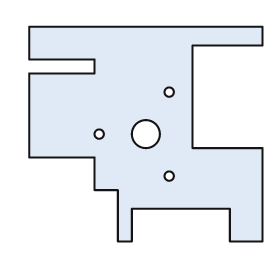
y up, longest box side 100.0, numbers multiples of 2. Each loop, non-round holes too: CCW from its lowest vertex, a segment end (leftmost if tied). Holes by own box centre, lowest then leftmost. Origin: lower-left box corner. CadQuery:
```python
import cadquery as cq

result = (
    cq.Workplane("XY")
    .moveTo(38.0, 0.0)
    .lineTo(44.0, 0.0)
    .lineTo(44.0, 14.0)
    .lineTo(86.0, 14.0)
    .lineTo(86.0, 0.0)
    .lineTo(100.0, 0.0)
    .lineTo(100.0, 40.0)
    .lineTo(70.0, 40.0)
    .lineTo(70.0, 84.0)
    .lineTo(100.0, 84.0)
    .lineTo(100.0, 92.0)
    .lineTo(0.0, 92.0)
    .lineTo(0.0, 78.0)
    .lineTo(28.0, 78.0)
    .lineTo(28.0, 72.0)
    .lineTo(0.0, 72.0)
    .lineTo(0.0, 36.0)
    .lineTo(28.0, 36.0)
    .lineTo(28.0, 22.0)
    .lineTo(38.0, 22.0)
    .close()
    .moveTo(60.0, 28.0)
    .circle(2.0)
    .moveTo(30.0, 46.0)
    .circle(2.0)
    .moveTo(50.0, 46.0)
    .circle(6.0)
    .moveTo(60.0, 64.0)
    .circle(2.0)
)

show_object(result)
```